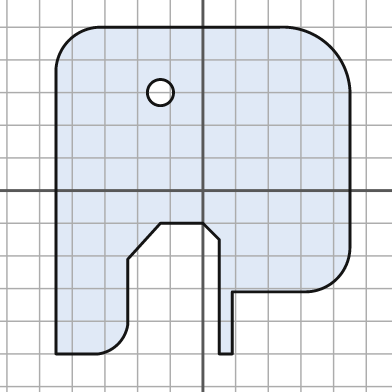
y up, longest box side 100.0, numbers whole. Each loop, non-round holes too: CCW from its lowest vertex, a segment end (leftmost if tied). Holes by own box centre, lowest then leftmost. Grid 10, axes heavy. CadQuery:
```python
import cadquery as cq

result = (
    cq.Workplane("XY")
    .moveTo(-45.0, -50.0)
    .lineTo(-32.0, -50.0)
    .threePointArc((-26.0, -47.0), (-23.0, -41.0))
    .lineTo(-23.0, -21.0)
    .lineTo(-13.0, -10.0)
    .lineTo(0.0, -10.0)
    .lineTo(5.0, -15.0)
    .lineTo(5.0, -50.0)
    .lineTo(9.0, -50.0)
    .lineTo(9.0, -31.0)
    .lineTo(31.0, -31.0)
    .threePointArc((41.0, -27.0), (45.0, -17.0))
    .lineTo(45.0, 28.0)
    .threePointArc((39.0, 44.0), (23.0, 50.0))
    .lineTo(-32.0, 50.0)
    .threePointArc((-41.0, 46.0), (-45.0, 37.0))
    .close()
    .moveTo(-13.0, 30.0)
    .circle(4.0)
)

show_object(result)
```